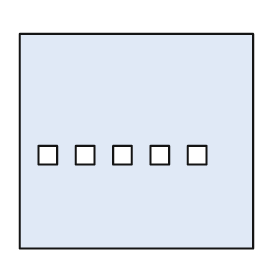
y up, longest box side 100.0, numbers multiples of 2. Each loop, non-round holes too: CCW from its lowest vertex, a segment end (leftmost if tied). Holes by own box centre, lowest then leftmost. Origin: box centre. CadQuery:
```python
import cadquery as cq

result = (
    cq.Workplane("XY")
    .moveTo(-50.0, -46.0)
    .lineTo(50.0, -46.0)
    .lineTo(50.0, 46.0)
    .lineTo(-50.0, 46.0)
    .close()
    .moveTo(-42.0, -10.0)
    .lineTo(-34.0, -10.0)
    .lineTo(-34.0, -2.0)
    .lineTo(-42.0, -2.0)
    .close()
    .moveTo(-26.0, -10.0)
    .lineTo(-18.0, -10.0)
    .lineTo(-18.0, -2.0)
    .lineTo(-26.0, -2.0)
    .close()
    .moveTo(-10.0, -10.0)
    .lineTo(-2.0, -10.0)
    .lineTo(-2.0, -2.0)
    .lineTo(-10.0, -2.0)
    .close()
    .moveTo(6.0, -10.0)
    .lineTo(14.0, -10.0)
    .lineTo(14.0, -2.0)
    .lineTo(6.0, -2.0)
    .close()
    .moveTo(22.0, -10.0)
    .lineTo(30.0, -10.0)
    .lineTo(30.0, -2.0)
    .lineTo(22.0, -2.0)
    .close()
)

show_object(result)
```